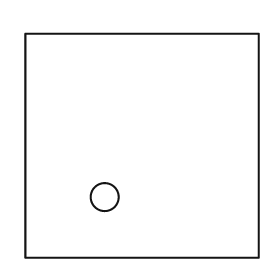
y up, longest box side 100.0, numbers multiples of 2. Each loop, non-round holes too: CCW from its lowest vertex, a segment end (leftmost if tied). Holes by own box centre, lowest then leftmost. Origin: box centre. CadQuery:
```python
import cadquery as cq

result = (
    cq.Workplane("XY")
    .moveTo(-50.0, -48.0)
    .lineTo(50.0, -48.0)
    .lineTo(50.0, 48.0)
    .lineTo(-50.0, 48.0)
    .close()
    .moveTo(-16.0, -22.0)
    .circle(6.0)
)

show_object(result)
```